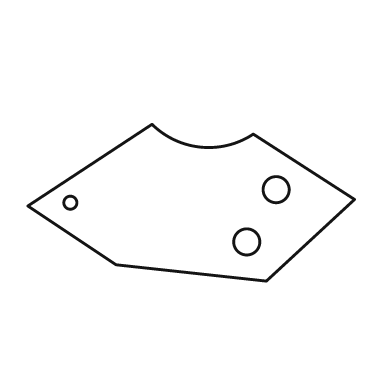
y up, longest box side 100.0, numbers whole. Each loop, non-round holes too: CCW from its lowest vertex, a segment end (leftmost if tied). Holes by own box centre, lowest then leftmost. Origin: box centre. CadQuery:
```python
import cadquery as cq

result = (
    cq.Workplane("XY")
    .moveTo(23.0, -24.0)
    .lineTo(50.0, 1.0)
    .lineTo(19.0, 21.0)
    .threePointArc((3.0, 17.0), (-12.0, 24.0))
    .lineTo(-50.0, -1.0)
    .lineTo(-23.0, -19.0)
    .close()
    .moveTo(17.0, -12.0)
    .circle(4.0)
    .moveTo(-37.0, 0.0)
    .circle(2.0)
    .moveTo(26.0, 4.0)
    .circle(4.0)
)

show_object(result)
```